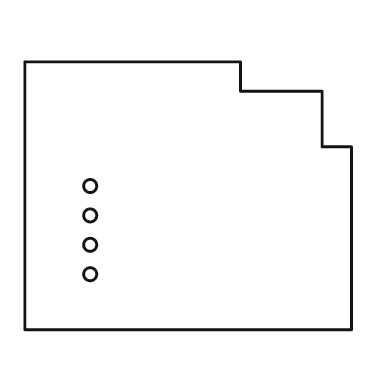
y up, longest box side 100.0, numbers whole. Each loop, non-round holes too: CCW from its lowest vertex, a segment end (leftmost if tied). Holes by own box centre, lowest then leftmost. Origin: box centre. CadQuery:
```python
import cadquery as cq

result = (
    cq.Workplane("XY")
    .moveTo(-50.0, -41.0)
    .lineTo(50.0, -41.0)
    .lineTo(50.0, 15.0)
    .lineTo(41.0, 15.0)
    .lineTo(41.0, 32.0)
    .lineTo(16.0, 32.0)
    .lineTo(16.0, 41.0)
    .lineTo(-50.0, 41.0)
    .close()
    .moveTo(-30.0, -24.0)
    .circle(2.0)
    .moveTo(-30.0, -15.0)
    .circle(2.0)
    .moveTo(-30.0, -6.0)
    .circle(2.0)
    .moveTo(-30.0, 3.0)
    .circle(2.0)
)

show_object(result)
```